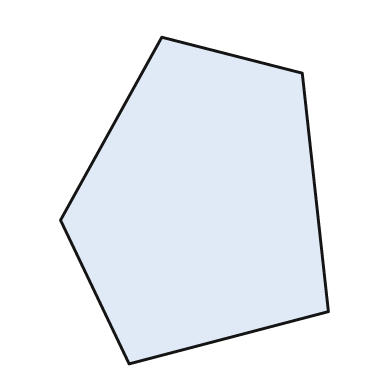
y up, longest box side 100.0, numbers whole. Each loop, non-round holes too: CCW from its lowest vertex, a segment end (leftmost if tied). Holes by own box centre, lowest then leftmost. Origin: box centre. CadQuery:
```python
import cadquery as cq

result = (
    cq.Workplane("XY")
    .moveTo(-20.0, -50.0)
    .lineTo(41.0, -34.0)
    .lineTo(33.0, 39.0)
    .lineTo(-10.0, 50.0)
    .lineTo(-41.0, -6.0)
    .close()
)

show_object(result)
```